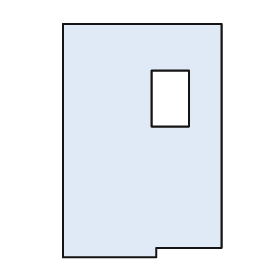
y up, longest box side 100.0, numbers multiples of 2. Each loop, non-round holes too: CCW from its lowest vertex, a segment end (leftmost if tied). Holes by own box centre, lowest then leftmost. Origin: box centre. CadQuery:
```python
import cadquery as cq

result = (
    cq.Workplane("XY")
    .moveTo(-34.0, -50.0)
    .lineTo(6.0, -50.0)
    .lineTo(6.0, -46.0)
    .lineTo(34.0, -46.0)
    .lineTo(34.0, 50.0)
    .lineTo(-34.0, 50.0)
    .close()
    .moveTo(4.0, 6.0)
    .lineTo(20.0, 6.0)
    .lineTo(20.0, 30.0)
    .lineTo(4.0, 30.0)
    .close()
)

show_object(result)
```